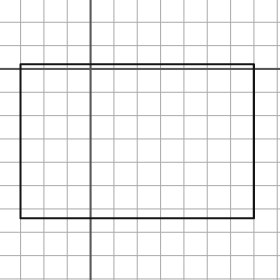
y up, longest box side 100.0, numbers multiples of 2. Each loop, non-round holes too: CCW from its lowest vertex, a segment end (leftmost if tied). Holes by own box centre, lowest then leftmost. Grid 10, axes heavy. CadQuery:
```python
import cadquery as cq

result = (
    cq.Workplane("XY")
    .moveTo(-30.0, -64.0)
    .lineTo(70.0, -64.0)
    .lineTo(70.0, 2.0)
    .lineTo(-30.0, 2.0)
    .close()
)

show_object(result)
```